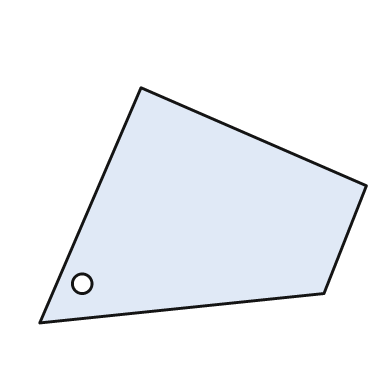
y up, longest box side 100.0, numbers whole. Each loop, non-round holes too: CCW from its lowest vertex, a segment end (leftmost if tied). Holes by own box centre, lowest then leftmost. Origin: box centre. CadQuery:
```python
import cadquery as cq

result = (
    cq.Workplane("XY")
    .moveTo(-50.0, -36.0)
    .lineTo(37.0, -27.0)
    .lineTo(50.0, 6.0)
    .lineTo(-19.0, 36.0)
    .close()
    .moveTo(-37.0, -24.0)
    .circle(3.0)
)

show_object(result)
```